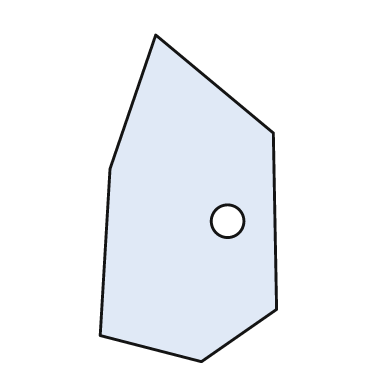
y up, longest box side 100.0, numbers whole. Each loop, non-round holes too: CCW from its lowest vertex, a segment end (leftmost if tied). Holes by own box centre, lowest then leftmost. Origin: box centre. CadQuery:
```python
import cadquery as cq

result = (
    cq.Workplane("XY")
    .moveTo(4.0, -50.0)
    .lineTo(27.0, -34.0)
    .lineTo(26.0, 20.0)
    .lineTo(-10.0, 50.0)
    .lineTo(-24.0, 9.0)
    .lineTo(-27.0, -42.0)
    .close()
    .moveTo(12.0, -7.0)
    .circle(5.0)
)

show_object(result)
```